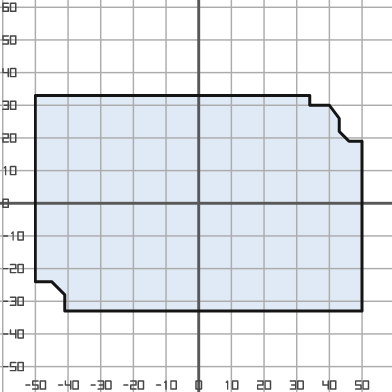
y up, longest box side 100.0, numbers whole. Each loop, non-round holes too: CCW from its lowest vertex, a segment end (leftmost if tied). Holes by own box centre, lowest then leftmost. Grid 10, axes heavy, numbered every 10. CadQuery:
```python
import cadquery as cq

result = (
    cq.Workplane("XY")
    .moveTo(-41.0, -33.0)
    .lineTo(50.0, -33.0)
    .lineTo(50.0, 19.0)
    .lineTo(46.0, 19.0)
    .lineTo(43.0, 22.0)
    .lineTo(43.0, 26.0)
    .lineTo(40.0, 30.0)
    .lineTo(34.0, 30.0)
    .lineTo(34.0, 33.0)
    .lineTo(-50.0, 33.0)
    .lineTo(-50.0, -24.0)
    .lineTo(-45.0, -24.0)
    .lineTo(-41.0, -28.0)
    .close()
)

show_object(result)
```